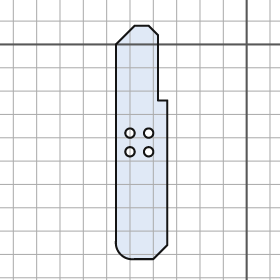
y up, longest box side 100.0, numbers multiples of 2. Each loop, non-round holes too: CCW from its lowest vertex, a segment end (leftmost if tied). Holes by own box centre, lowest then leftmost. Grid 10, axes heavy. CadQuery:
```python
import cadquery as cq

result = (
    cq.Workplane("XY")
    .moveTo(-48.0, -92.0)
    .lineTo(-40.0, -92.0)
    .lineTo(-34.0, -86.0)
    .lineTo(-34.0, -24.0)
    .lineTo(-38.0, -24.0)
    .lineTo(-38.0, 4.0)
    .lineTo(-42.0, 8.0)
    .lineTo(-48.0, 8.0)
    .lineTo(-56.0, 0.0)
    .lineTo(-56.0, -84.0)
    .threePointArc((-54.0, -90.0), (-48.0, -92.0))
    .close()
    .moveTo(-50.0, -46.0)
    .circle(2.0)
    .moveTo(-42.0, -46.0)
    .circle(2.0)
    .moveTo(-50.0, -38.0)
    .circle(2.0)
    .moveTo(-42.0, -38.0)
    .circle(2.0)
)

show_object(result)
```